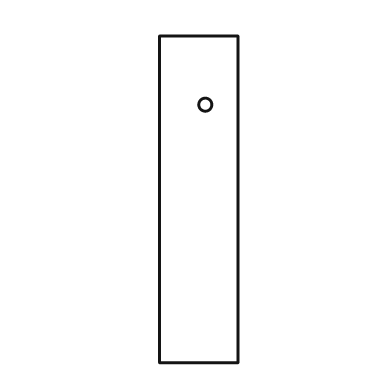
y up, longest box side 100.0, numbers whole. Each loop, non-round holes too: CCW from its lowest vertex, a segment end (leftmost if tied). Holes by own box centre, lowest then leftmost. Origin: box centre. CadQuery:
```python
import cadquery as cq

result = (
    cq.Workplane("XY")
    .moveTo(-12.0, -50.0)
    .lineTo(12.0, -50.0)
    .lineTo(12.0, 50.0)
    .lineTo(-12.0, 50.0)
    .close()
    .moveTo(2.0, 29.0)
    .circle(2.0)
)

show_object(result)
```